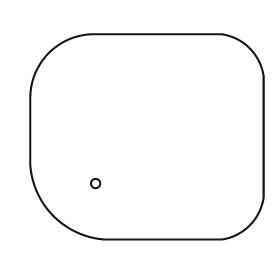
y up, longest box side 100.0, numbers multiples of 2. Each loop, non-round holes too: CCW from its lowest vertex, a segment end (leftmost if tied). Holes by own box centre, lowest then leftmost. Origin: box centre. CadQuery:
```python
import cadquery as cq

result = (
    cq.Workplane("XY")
    .moveTo(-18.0, -44.0)
    .lineTo(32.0, -44.0)
    .threePointArc((44.0, -38.0), (50.0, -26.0))
    .lineTo(50.0, 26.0)
    .threePointArc((44.0, 38.0), (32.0, 44.0))
    .lineTo(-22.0, 44.0)
    .threePointArc((-42.0, 36.0), (-50.0, 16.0))
    .lineTo(-50.0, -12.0)
    .threePointArc((-40.0, -34.0), (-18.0, -44.0))
    .close()
    .moveTo(-22.0, -20.0)
    .circle(2.0)
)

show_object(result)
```